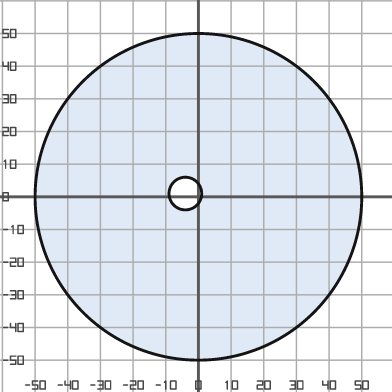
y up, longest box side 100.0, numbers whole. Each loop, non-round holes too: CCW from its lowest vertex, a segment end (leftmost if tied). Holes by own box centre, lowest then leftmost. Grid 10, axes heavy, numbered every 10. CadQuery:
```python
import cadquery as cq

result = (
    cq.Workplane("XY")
    .moveTo(0.0, 0.0)
    .circle(50.0)
    .moveTo(-4.0, 1.0)
    .circle(5.0)
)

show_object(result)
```